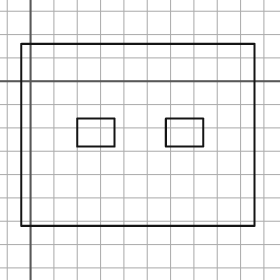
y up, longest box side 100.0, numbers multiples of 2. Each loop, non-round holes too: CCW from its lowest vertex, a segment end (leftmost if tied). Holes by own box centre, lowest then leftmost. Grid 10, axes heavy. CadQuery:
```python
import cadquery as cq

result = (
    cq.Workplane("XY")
    .moveTo(-4.0, -62.0)
    .lineTo(96.0, -62.0)
    .lineTo(96.0, 16.0)
    .lineTo(-4.0, 16.0)
    .close()
    .moveTo(20.0, -28.0)
    .lineTo(36.0, -28.0)
    .lineTo(36.0, -16.0)
    .lineTo(20.0, -16.0)
    .close()
    .moveTo(58.0, -28.0)
    .lineTo(74.0, -28.0)
    .lineTo(74.0, -16.0)
    .lineTo(58.0, -16.0)
    .close()
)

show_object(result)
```